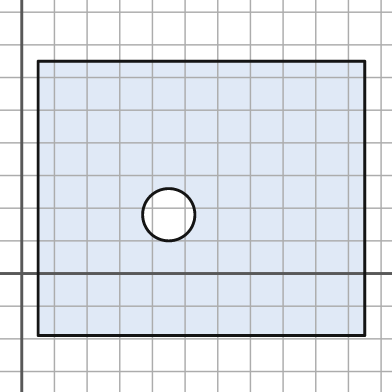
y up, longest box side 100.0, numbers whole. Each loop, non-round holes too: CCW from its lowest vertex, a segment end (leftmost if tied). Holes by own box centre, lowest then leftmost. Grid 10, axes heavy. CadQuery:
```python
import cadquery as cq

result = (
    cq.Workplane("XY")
    .moveTo(5.0, -19.0)
    .lineTo(105.0, -19.0)
    .lineTo(105.0, 65.0)
    .lineTo(5.0, 65.0)
    .close()
    .moveTo(45.0, 18.0)
    .circle(8.0)
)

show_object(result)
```